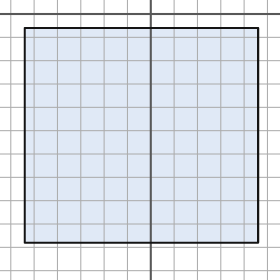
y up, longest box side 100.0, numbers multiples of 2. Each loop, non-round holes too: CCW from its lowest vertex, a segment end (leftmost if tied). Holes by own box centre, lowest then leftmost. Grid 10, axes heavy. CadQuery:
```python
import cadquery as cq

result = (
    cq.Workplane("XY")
    .moveTo(-54.0, -98.0)
    .lineTo(46.0, -98.0)
    .lineTo(46.0, -6.0)
    .lineTo(-54.0, -6.0)
    .close()
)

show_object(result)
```